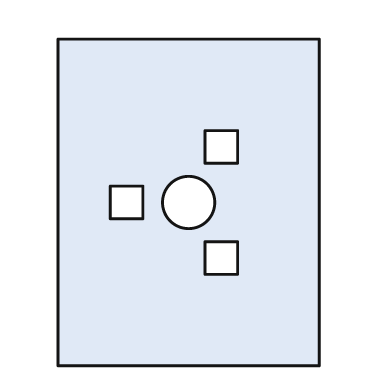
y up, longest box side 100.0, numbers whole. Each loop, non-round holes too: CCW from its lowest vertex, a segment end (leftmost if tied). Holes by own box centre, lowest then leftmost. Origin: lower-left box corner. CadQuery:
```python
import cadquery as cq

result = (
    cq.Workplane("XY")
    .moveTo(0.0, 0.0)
    .lineTo(80.0, 0.0)
    .lineTo(80.0, 100.0)
    .lineTo(0.0, 100.0)
    .close()
    .moveTo(45.0, 28.0)
    .lineTo(55.0, 28.0)
    .lineTo(55.0, 38.0)
    .lineTo(45.0, 38.0)
    .close()
    .moveTo(16.0, 45.0)
    .lineTo(26.0, 45.0)
    .lineTo(26.0, 55.0)
    .lineTo(16.0, 55.0)
    .close()
    .moveTo(40.0, 50.0)
    .circle(8.0)
    .moveTo(45.0, 62.0)
    .lineTo(55.0, 62.0)
    .lineTo(55.0, 72.0)
    .lineTo(45.0, 72.0)
    .close()
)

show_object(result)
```